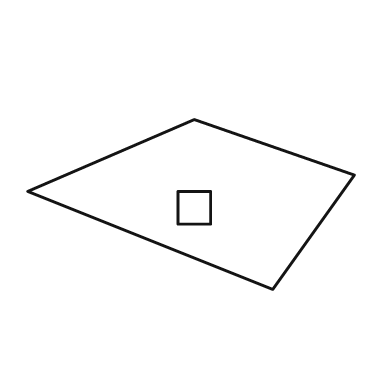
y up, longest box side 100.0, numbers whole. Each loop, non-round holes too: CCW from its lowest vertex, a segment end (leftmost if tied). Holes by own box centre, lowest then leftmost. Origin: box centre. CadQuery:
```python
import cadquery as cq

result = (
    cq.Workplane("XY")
    .moveTo(25.0, -26.0)
    .lineTo(50.0, 9.0)
    .lineTo(1.0, 26.0)
    .lineTo(-50.0, 4.0)
    .close()
    .moveTo(-4.0, -6.0)
    .lineTo(6.0, -6.0)
    .lineTo(6.0, 4.0)
    .lineTo(-4.0, 4.0)
    .close()
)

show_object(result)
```